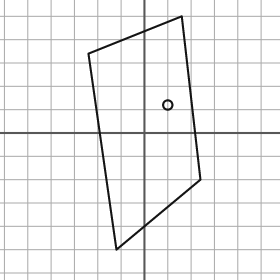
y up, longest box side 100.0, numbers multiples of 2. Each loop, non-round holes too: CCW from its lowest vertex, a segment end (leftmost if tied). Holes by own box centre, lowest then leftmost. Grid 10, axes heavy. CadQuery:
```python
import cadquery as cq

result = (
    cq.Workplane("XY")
    .moveTo(-12.0, -50.0)
    .lineTo(24.0, -20.0)
    .lineTo(16.0, 50.0)
    .lineTo(-24.0, 34.0)
    .close()
    .moveTo(10.0, 12.0)
    .circle(2.0)
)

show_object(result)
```